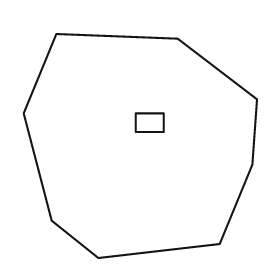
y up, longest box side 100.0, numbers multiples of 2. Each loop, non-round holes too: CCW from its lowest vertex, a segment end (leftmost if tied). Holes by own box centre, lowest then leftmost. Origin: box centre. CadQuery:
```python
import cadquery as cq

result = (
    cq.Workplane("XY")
    .moveTo(-18.0, -48.0)
    .lineTo(34.0, -42.0)
    .lineTo(48.0, -8.0)
    .lineTo(50.0, 20.0)
    .lineTo(16.0, 46.0)
    .lineTo(-36.0, 48.0)
    .lineTo(-50.0, 14.0)
    .lineTo(-38.0, -32.0)
    .close()
    .moveTo(-2.0, 6.0)
    .lineTo(10.0, 6.0)
    .lineTo(10.0, 14.0)
    .lineTo(-2.0, 14.0)
    .close()
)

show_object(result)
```